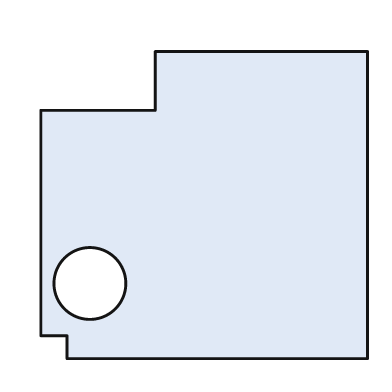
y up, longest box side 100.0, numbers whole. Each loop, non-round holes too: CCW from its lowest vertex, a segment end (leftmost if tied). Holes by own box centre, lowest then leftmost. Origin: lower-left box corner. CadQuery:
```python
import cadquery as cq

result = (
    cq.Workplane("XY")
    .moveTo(8.0, 0.0)
    .lineTo(100.0, 0.0)
    .lineTo(100.0, 94.0)
    .lineTo(35.0, 94.0)
    .lineTo(35.0, 76.0)
    .lineTo(0.0, 76.0)
    .lineTo(0.0, 7.0)
    .lineTo(8.0, 7.0)
    .close()
    .moveTo(15.0, 23.0)
    .circle(11.0)
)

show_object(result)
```